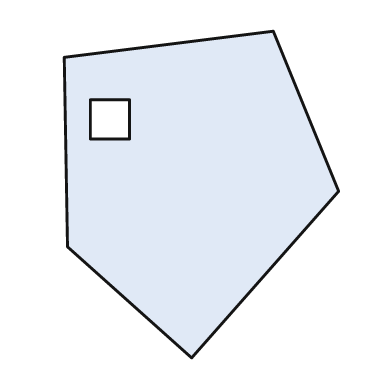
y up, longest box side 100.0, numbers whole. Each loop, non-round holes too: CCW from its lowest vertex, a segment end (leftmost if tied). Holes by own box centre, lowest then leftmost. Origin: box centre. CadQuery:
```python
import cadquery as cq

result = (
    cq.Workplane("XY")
    .moveTo(-3.0, -50.0)
    .lineTo(42.0, 1.0)
    .lineTo(22.0, 50.0)
    .lineTo(-42.0, 42.0)
    .lineTo(-41.0, -16.0)
    .close()
    .moveTo(-34.0, 17.0)
    .lineTo(-22.0, 17.0)
    .lineTo(-22.0, 29.0)
    .lineTo(-34.0, 29.0)
    .close()
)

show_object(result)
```